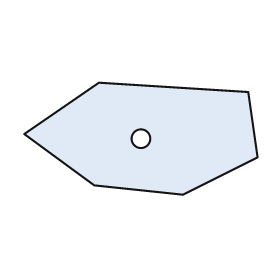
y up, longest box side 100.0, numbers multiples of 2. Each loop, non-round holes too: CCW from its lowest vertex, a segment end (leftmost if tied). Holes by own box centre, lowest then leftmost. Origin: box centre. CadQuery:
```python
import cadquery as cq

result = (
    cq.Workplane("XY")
    .moveTo(18.0, -24.0)
    .lineTo(50.0, -8.0)
    .lineTo(46.0, 20.0)
    .lineTo(-18.0, 24.0)
    .lineTo(-50.0, 2.0)
    .lineTo(-20.0, -20.0)
    .close()
    .moveTo(0.0, 0.0)
    .circle(4.0)
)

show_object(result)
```